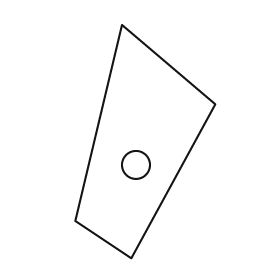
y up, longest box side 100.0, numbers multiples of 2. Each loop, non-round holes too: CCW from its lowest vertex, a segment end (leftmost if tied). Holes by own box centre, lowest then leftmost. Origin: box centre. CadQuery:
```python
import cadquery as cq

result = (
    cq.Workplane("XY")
    .moveTo(-6.0, -50.0)
    .lineTo(30.0, 16.0)
    .lineTo(-10.0, 50.0)
    .lineTo(-30.0, -34.0)
    .close()
    .moveTo(-4.0, -10.0)
    .circle(6.0)
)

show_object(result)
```